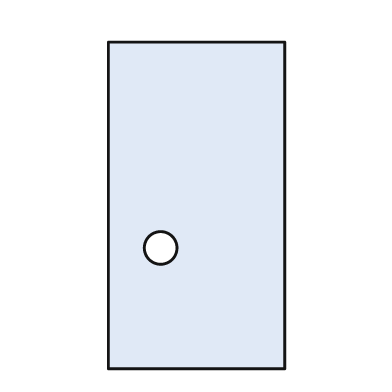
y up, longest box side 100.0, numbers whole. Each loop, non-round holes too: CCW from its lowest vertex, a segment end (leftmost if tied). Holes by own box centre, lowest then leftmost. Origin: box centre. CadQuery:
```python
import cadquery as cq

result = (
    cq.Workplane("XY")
    .moveTo(-27.0, -50.0)
    .lineTo(27.0, -50.0)
    .lineTo(27.0, 50.0)
    .lineTo(-27.0, 50.0)
    .close()
    .moveTo(-11.0, -13.0)
    .circle(5.0)
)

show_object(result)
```